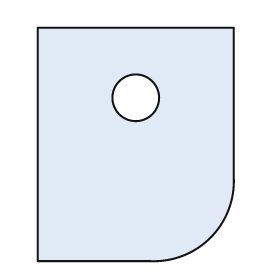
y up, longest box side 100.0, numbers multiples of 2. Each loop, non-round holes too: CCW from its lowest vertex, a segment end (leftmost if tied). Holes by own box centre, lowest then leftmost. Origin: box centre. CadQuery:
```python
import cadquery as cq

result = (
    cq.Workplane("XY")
    .moveTo(-42.0, -50.0)
    .lineTo(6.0, -50.0)
    .threePointArc((32.0, -40.0), (42.0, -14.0))
    .lineTo(42.0, 50.0)
    .lineTo(-42.0, 50.0)
    .close()
    .moveTo(0.0, 20.0)
    .circle(10.0)
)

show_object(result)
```